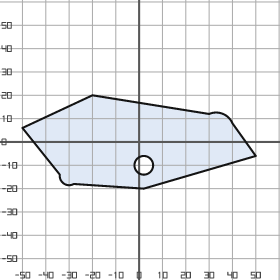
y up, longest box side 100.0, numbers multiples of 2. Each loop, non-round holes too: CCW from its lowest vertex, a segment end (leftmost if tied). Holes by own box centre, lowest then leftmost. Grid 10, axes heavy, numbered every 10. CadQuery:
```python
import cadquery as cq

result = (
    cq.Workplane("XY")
    .moveTo(2.0, -20.0)
    .lineTo(50.0, -6.0)
    .lineTo(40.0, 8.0)
    .threePointArc((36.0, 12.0), (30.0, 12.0))
    .lineTo(-20.0, 20.0)
    .lineTo(-50.0, 6.0)
    .lineTo(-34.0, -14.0)
    .threePointArc((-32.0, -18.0), (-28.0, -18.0))
    .close()
    .moveTo(2.0, -10.0)
    .circle(4.0)
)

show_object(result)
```